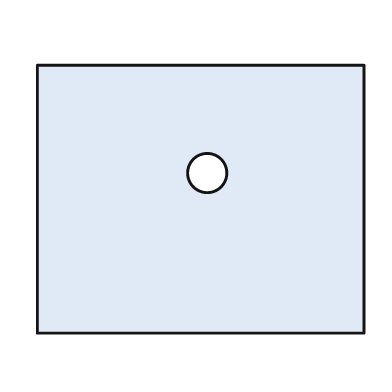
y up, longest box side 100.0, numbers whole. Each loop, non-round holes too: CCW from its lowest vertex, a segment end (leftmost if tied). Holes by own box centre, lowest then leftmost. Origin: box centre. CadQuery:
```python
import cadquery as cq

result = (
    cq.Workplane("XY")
    .moveTo(-50.0, -41.0)
    .lineTo(50.0, -41.0)
    .lineTo(50.0, 41.0)
    .lineTo(-50.0, 41.0)
    .close()
    .moveTo(2.0, 8.0)
    .circle(6.0)
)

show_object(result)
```